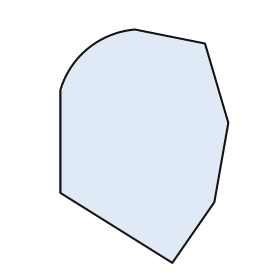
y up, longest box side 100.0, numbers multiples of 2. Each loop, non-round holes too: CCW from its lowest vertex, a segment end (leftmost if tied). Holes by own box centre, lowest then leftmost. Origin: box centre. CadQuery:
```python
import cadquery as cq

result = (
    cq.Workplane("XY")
    .moveTo(12.0, -50.0)
    .lineTo(30.0, -24.0)
    .lineTo(36.0, 10.0)
    .lineTo(26.0, 44.0)
    .lineTo(-4.0, 50.0)
    .threePointArc((-24.0, 42.0), (-36.0, 24.0))
    .lineTo(-36.0, -20.0)
    .close()
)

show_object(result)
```